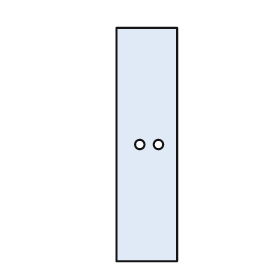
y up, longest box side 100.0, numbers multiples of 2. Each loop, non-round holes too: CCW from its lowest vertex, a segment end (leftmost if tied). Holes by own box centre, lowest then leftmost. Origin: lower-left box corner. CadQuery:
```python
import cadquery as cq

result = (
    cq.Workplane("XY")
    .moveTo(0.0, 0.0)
    .lineTo(26.0, 0.0)
    .lineTo(26.0, 100.0)
    .lineTo(0.0, 100.0)
    .close()
    .moveTo(10.0, 50.0)
    .circle(2.0)
    .moveTo(18.0, 50.0)
    .circle(2.0)
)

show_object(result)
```